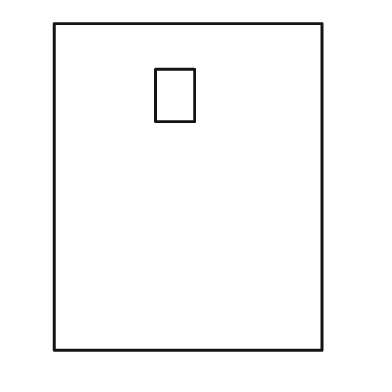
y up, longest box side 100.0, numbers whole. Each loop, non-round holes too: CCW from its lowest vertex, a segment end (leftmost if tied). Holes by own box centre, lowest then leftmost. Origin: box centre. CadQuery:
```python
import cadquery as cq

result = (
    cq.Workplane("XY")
    .moveTo(-41.0, -50.0)
    .lineTo(41.0, -50.0)
    .lineTo(41.0, 50.0)
    .lineTo(-41.0, 50.0)
    .close()
    .moveTo(-10.0, 20.0)
    .lineTo(2.0, 20.0)
    .lineTo(2.0, 36.0)
    .lineTo(-10.0, 36.0)
    .close()
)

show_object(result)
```